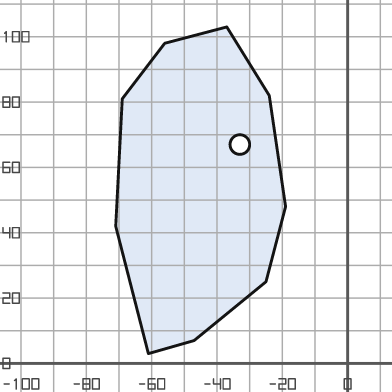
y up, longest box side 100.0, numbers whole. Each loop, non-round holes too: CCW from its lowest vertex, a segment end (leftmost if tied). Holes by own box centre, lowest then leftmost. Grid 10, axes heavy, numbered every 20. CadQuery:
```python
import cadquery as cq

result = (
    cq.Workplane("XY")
    .moveTo(-61.0, 3.0)
    .lineTo(-47.0, 7.0)
    .lineTo(-25.0, 25.0)
    .lineTo(-19.0, 48.0)
    .lineTo(-24.0, 82.0)
    .lineTo(-37.0, 103.0)
    .lineTo(-56.0, 98.0)
    .lineTo(-69.0, 81.0)
    .lineTo(-71.0, 42.0)
    .close()
    .moveTo(-33.0, 67.0)
    .circle(3.0)
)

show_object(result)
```